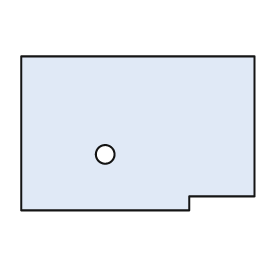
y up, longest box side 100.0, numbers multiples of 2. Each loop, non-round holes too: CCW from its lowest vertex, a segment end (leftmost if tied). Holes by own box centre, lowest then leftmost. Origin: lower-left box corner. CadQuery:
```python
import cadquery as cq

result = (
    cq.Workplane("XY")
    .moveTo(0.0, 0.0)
    .lineTo(72.0, 0.0)
    .lineTo(72.0, 6.0)
    .lineTo(100.0, 6.0)
    .lineTo(100.0, 66.0)
    .lineTo(0.0, 66.0)
    .close()
    .moveTo(36.0, 24.0)
    .circle(4.0)
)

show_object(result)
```